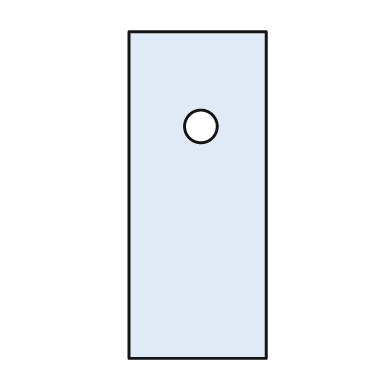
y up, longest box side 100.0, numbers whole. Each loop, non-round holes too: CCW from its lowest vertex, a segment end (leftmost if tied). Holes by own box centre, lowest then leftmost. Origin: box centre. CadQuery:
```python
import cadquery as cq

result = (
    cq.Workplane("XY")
    .moveTo(-21.0, -50.0)
    .lineTo(21.0, -50.0)
    .lineTo(21.0, 50.0)
    .lineTo(-21.0, 50.0)
    .close()
    .moveTo(1.0, 21.0)
    .circle(5.0)
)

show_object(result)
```